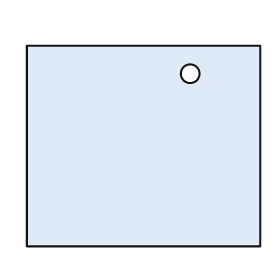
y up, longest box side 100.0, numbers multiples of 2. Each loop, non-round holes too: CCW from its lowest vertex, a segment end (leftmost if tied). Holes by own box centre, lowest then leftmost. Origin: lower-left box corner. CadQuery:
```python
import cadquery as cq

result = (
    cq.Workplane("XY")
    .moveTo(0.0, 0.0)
    .lineTo(100.0, 0.0)
    .lineTo(100.0, 86.0)
    .lineTo(0.0, 86.0)
    .close()
    .moveTo(70.0, 74.0)
    .circle(4.0)
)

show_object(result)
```